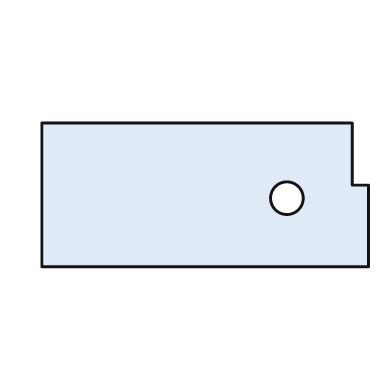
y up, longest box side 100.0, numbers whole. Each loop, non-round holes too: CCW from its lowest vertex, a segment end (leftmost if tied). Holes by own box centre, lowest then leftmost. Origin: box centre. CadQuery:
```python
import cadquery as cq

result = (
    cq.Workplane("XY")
    .moveTo(-50.0, -22.0)
    .lineTo(50.0, -22.0)
    .lineTo(50.0, 3.0)
    .lineTo(45.0, 3.0)
    .lineTo(45.0, 22.0)
    .lineTo(-50.0, 22.0)
    .close()
    .moveTo(25.0, -1.0)
    .circle(5.0)
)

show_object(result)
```